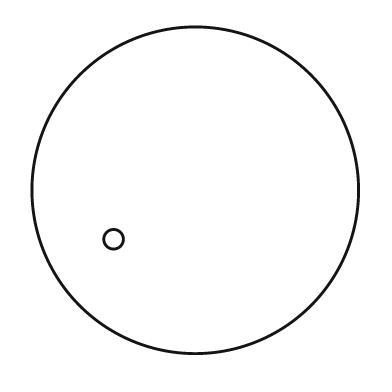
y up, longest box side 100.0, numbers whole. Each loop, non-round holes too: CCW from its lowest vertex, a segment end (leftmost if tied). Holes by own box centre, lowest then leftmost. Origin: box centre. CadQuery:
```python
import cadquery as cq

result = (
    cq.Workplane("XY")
    .moveTo(0.0, 0.0)
    .circle(50.0)
    .moveTo(-25.0, -15.0)
    .circle(3.0)
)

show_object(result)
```